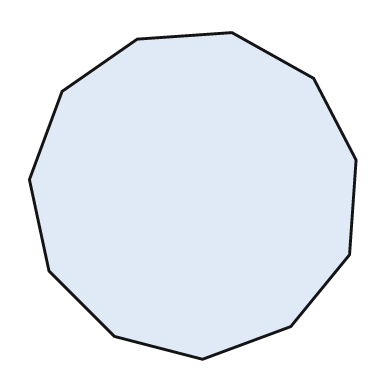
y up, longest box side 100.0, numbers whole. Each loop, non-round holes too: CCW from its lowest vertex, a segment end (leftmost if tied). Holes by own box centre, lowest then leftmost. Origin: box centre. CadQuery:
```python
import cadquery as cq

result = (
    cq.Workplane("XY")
    .moveTo(3.0, -50.0)
    .lineTo(30.0, -40.0)
    .lineTo(48.0, -18.0)
    .lineTo(50.0, 11.0)
    .lineTo(37.0, 36.0)
    .lineTo(12.0, 50.0)
    .lineTo(-17.0, 48.0)
    .lineTo(-40.0, 32.0)
    .lineTo(-50.0, 5.0)
    .lineTo(-44.0, -23.0)
    .lineTo(-24.0, -43.0)
    .close()
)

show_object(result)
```